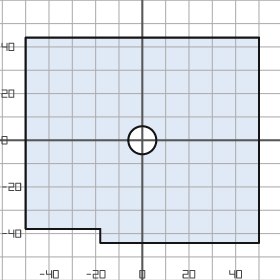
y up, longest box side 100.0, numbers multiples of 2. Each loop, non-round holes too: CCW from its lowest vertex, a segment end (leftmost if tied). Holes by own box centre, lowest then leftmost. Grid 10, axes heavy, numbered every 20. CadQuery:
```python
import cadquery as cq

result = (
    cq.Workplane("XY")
    .moveTo(-18.0, -44.0)
    .lineTo(50.0, -44.0)
    .lineTo(50.0, 44.0)
    .lineTo(-50.0, 44.0)
    .lineTo(-50.0, -38.0)
    .lineTo(-18.0, -38.0)
    .close()
    .moveTo(0.0, 0.0)
    .circle(6.0)
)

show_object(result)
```